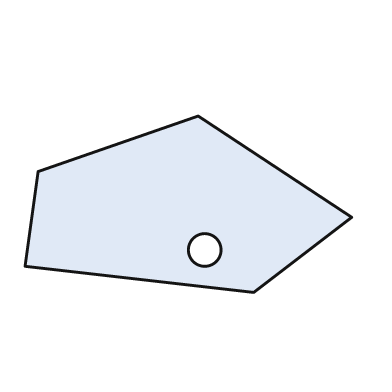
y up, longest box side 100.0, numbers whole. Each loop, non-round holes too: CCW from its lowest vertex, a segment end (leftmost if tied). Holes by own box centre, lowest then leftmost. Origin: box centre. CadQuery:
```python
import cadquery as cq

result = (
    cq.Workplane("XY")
    .moveTo(20.0, -27.0)
    .lineTo(50.0, -4.0)
    .lineTo(3.0, 27.0)
    .lineTo(-46.0, 10.0)
    .lineTo(-50.0, -19.0)
    .close()
    .moveTo(5.0, -14.0)
    .circle(5.0)
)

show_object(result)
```